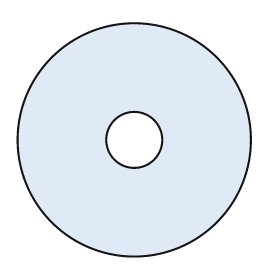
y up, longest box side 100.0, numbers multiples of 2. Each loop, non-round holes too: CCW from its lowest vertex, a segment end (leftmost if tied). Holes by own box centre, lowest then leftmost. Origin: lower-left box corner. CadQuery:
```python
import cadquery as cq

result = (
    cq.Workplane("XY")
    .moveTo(50.0, 50.0)
    .circle(50.0)
    .moveTo(50.0, 50.0)
    .circle(12.0)
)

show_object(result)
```